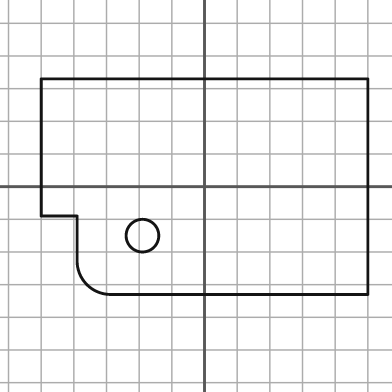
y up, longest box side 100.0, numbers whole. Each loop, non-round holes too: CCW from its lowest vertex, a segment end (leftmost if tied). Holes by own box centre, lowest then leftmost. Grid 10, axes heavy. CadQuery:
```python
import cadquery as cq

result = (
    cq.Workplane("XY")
    .moveTo(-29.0, -33.0)
    .lineTo(50.0, -33.0)
    .lineTo(50.0, 33.0)
    .lineTo(-50.0, 33.0)
    .lineTo(-50.0, -9.0)
    .lineTo(-39.0, -9.0)
    .lineTo(-39.0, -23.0)
    .threePointArc((-36.0, -30.0), (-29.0, -33.0))
    .close()
    .moveTo(-19.0, -15.0)
    .circle(5.0)
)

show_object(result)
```